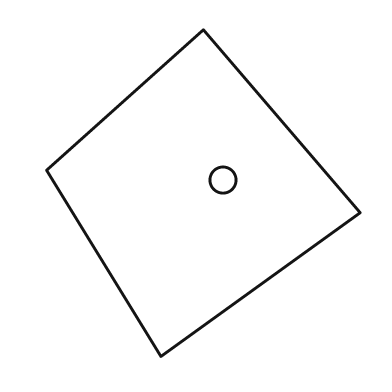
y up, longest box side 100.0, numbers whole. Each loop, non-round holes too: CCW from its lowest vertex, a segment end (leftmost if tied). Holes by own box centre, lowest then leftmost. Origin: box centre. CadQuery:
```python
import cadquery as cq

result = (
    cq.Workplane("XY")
    .moveTo(-13.0, -50.0)
    .lineTo(48.0, -6.0)
    .lineTo(0.0, 50.0)
    .lineTo(-48.0, 7.0)
    .close()
    .moveTo(6.0, 4.0)
    .circle(4.0)
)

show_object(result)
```